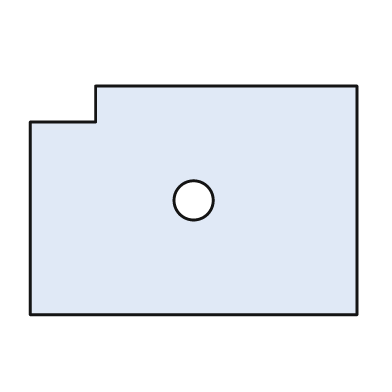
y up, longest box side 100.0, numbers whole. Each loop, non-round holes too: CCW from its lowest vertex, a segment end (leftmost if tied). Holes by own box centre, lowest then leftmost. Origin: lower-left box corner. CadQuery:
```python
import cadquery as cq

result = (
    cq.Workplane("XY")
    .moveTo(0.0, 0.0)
    .lineTo(100.0, 0.0)
    .lineTo(100.0, 70.0)
    .lineTo(20.0, 70.0)
    .lineTo(20.0, 59.0)
    .lineTo(0.0, 59.0)
    .close()
    .moveTo(50.0, 35.0)
    .circle(6.0)
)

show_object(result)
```